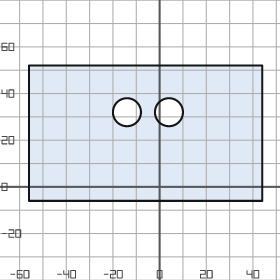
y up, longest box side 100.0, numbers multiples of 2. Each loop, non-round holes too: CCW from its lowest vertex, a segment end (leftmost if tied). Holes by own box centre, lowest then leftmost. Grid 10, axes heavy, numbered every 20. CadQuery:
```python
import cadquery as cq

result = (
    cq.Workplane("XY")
    .moveTo(-56.0, -6.0)
    .lineTo(44.0, -6.0)
    .lineTo(44.0, 52.0)
    .lineTo(-56.0, 52.0)
    .close()
    .moveTo(-14.0, 32.0)
    .circle(6.0)
    .moveTo(4.0, 32.0)
    .circle(6.0)
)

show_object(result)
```